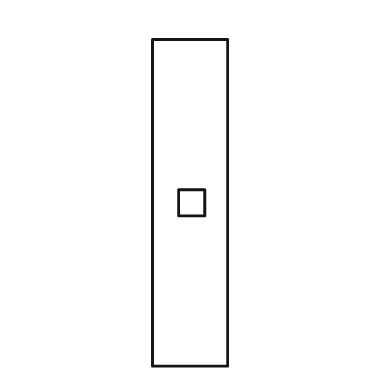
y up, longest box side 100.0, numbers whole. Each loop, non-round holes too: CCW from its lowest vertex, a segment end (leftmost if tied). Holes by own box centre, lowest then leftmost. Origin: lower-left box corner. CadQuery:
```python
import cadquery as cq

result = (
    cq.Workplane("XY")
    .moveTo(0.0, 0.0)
    .lineTo(23.0, 0.0)
    .lineTo(23.0, 100.0)
    .lineTo(0.0, 100.0)
    .close()
    .moveTo(8.0, 46.0)
    .lineTo(16.0, 46.0)
    .lineTo(16.0, 54.0)
    .lineTo(8.0, 54.0)
    .close()
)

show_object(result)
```